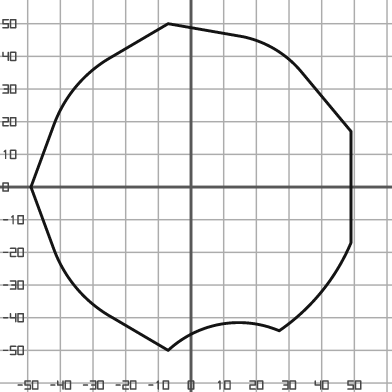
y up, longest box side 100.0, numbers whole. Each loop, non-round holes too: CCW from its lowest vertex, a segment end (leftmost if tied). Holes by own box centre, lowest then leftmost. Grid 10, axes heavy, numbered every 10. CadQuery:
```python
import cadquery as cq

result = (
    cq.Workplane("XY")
    .moveTo(-7.0, -50.0)
    .threePointArc((9.0, -42.0), (27.0, -44.0))
    .threePointArc((40.0, -32.0), (49.0, -17.0))
    .lineTo(49.0, 17.0)
    .lineTo(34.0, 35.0)
    .threePointArc((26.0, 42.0), (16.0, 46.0))
    .lineTo(-7.0, 50.0)
    .lineTo(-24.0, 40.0)
    .threePointArc((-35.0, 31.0), (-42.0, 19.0))
    .lineTo(-49.0, 0.0)
    .lineTo(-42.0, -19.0)
    .threePointArc((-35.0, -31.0), (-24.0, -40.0))
    .close()
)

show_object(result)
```